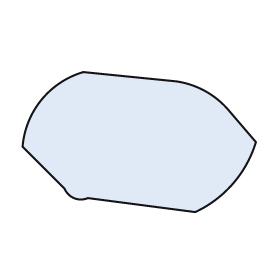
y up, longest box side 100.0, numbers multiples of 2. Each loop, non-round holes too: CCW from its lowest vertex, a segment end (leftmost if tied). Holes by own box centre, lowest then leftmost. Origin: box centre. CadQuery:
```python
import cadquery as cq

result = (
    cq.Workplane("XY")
    .moveTo(24.0, -30.0)
    .threePointArc((40.0, -18.0), (50.0, 0.0))
    .lineTo(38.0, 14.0)
    .threePointArc((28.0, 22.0), (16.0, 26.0))
    .lineTo(-24.0, 30.0)
    .threePointArc((-42.0, 18.0), (-50.0, -2.0))
    .lineTo(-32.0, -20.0)
    .threePointArc((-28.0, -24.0), (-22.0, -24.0))
    .close()
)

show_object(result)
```